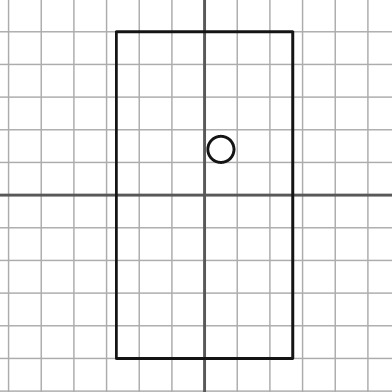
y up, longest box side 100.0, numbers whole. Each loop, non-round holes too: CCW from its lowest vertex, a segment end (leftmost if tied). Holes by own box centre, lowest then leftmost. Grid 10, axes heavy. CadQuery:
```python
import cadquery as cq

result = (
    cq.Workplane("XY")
    .moveTo(-27.0, -50.0)
    .lineTo(27.0, -50.0)
    .lineTo(27.0, 50.0)
    .lineTo(-27.0, 50.0)
    .close()
    .moveTo(5.0, 14.0)
    .circle(4.0)
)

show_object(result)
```